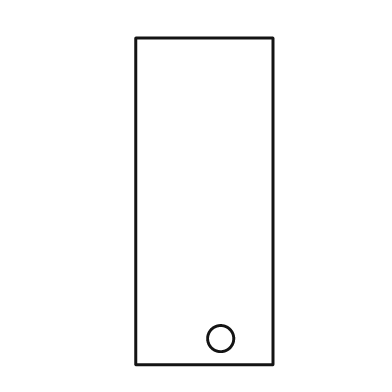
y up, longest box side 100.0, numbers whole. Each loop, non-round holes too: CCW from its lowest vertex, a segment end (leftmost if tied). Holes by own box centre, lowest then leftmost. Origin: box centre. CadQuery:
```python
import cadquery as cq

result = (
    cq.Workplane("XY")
    .moveTo(-21.0, -50.0)
    .lineTo(21.0, -50.0)
    .lineTo(21.0, 50.0)
    .lineTo(-21.0, 50.0)
    .close()
    .moveTo(5.0, -42.0)
    .circle(4.0)
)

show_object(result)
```